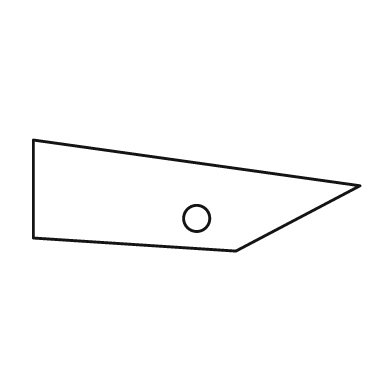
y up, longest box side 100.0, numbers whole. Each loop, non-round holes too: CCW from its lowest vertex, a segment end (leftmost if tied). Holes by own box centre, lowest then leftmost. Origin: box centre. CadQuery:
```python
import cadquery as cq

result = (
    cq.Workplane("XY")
    .moveTo(12.0, -17.0)
    .lineTo(50.0, 3.0)
    .lineTo(-50.0, 17.0)
    .lineTo(-50.0, -13.0)
    .close()
    .moveTo(0.0, -7.0)
    .circle(4.0)
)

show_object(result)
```